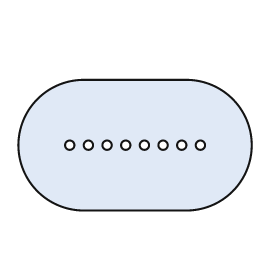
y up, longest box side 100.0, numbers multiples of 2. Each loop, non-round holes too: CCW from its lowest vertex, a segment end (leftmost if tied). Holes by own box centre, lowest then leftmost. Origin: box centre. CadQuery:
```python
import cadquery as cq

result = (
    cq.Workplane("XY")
    .moveTo(-22.0, -28.0)
    .lineTo(22.0, -28.0)
    .threePointArc((50.0, 0.0), (22.0, 28.0))
    .lineTo(-22.0, 28.0)
    .threePointArc((-50.0, 0.0), (-22.0, -28.0))
    .close()
    .moveTo(-28.0, 0.0)
    .circle(2.0)
    .moveTo(-20.0, 0.0)
    .circle(2.0)
    .moveTo(-12.0, 0.0)
    .circle(2.0)
    .moveTo(-4.0, 0.0)
    .circle(2.0)
    .moveTo(4.0, 0.0)
    .circle(2.0)
    .moveTo(12.0, 0.0)
    .circle(2.0)
    .moveTo(20.0, 0.0)
    .circle(2.0)
    .moveTo(28.0, 0.0)
    .circle(2.0)
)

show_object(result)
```